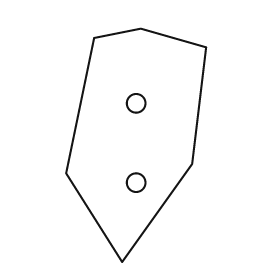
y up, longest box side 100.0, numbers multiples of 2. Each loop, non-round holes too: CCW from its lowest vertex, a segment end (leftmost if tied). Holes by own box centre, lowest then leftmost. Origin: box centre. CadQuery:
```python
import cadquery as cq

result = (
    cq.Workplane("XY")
    .moveTo(-6.0, -50.0)
    .lineTo(24.0, -8.0)
    .lineTo(30.0, 42.0)
    .lineTo(2.0, 50.0)
    .lineTo(-18.0, 46.0)
    .lineTo(-30.0, -12.0)
    .close()
    .moveTo(0.0, -16.0)
    .circle(4.0)
    .moveTo(0.0, 18.0)
    .circle(4.0)
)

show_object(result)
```